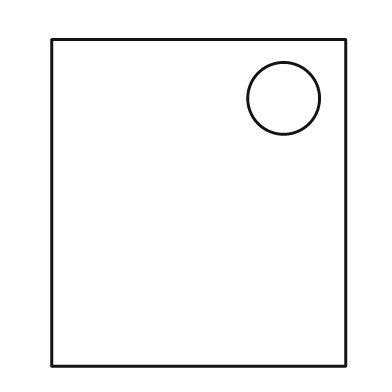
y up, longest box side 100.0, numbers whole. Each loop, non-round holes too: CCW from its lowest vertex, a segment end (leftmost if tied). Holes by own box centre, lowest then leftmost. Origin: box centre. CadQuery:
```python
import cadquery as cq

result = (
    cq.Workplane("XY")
    .moveTo(-45.0, -50.0)
    .lineTo(45.0, -50.0)
    .lineTo(45.0, 50.0)
    .lineTo(-45.0, 50.0)
    .close()
    .moveTo(26.0, 32.0)
    .circle(11.0)
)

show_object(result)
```